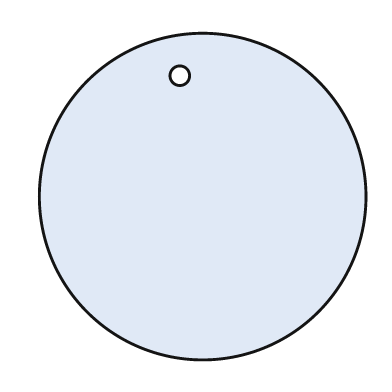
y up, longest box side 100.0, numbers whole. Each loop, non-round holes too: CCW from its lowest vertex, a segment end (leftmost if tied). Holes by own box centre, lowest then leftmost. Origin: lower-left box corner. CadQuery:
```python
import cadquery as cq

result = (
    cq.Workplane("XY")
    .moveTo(50.0, 50.0)
    .circle(50.0)
    .moveTo(43.0, 87.0)
    .circle(3.0)
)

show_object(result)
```